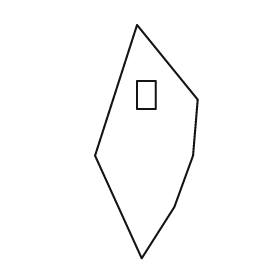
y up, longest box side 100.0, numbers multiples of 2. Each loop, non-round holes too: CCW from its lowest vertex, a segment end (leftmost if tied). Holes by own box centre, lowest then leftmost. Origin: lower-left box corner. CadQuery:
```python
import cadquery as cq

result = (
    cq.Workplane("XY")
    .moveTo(20.0, 0.0)
    .lineTo(34.0, 22.0)
    .lineTo(42.0, 44.0)
    .lineTo(44.0, 68.0)
    .lineTo(18.0, 100.0)
    .lineTo(0.0, 44.0)
    .close()
    .moveTo(18.0, 64.0)
    .lineTo(26.0, 64.0)
    .lineTo(26.0, 76.0)
    .lineTo(18.0, 76.0)
    .close()
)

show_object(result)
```